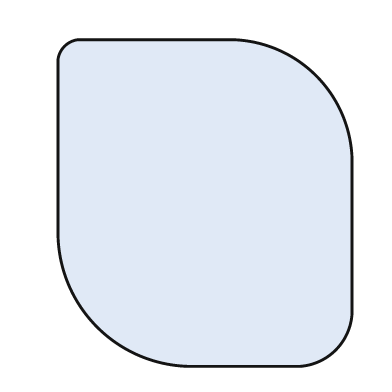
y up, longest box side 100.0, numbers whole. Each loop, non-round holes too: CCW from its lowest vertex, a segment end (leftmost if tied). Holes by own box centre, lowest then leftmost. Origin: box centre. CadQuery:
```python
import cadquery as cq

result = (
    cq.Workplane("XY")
    .moveTo(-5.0, -50.0)
    .lineTo(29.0, -50.0)
    .threePointArc((40.0, -45.0), (45.0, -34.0))
    .lineTo(45.0, 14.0)
    .threePointArc((34.0, 39.0), (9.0, 50.0))
    .lineTo(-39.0, 50.0)
    .threePointArc((-43.0, 48.0), (-45.0, 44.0))
    .lineTo(-45.0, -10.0)
    .threePointArc((-33.0, -38.0), (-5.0, -50.0))
    .close()
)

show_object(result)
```